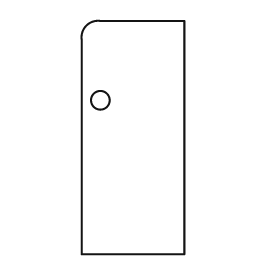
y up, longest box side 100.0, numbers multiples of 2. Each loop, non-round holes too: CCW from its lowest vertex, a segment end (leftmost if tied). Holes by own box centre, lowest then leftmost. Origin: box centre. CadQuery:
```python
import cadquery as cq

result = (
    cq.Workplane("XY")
    .moveTo(-22.0, -50.0)
    .lineTo(22.0, -50.0)
    .lineTo(22.0, 50.0)
    .lineTo(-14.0, 50.0)
    .threePointArc((-20.0, 48.0), (-22.0, 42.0))
    .close()
    .moveTo(-14.0, 16.0)
    .circle(4.0)
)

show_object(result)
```